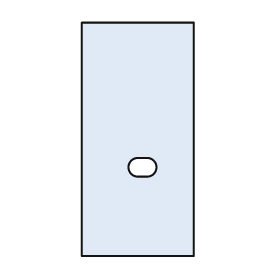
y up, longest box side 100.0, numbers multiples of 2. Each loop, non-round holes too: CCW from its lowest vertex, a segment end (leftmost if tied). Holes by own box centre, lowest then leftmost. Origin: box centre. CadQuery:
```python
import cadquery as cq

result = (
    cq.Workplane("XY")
    .moveTo(-24.0, -50.0)
    .lineTo(24.0, -50.0)
    .lineTo(24.0, 50.0)
    .lineTo(-24.0, 50.0)
    .close()
    .moveTo(0.0, -16.0)
    .lineTo(4.0, -16.0)
    .threePointArc((8.0, -12.0), (4.0, -8.0))
    .lineTo(0.0, -8.0)
    .threePointArc((-4.0, -12.0), (0.0, -16.0))
    .close()
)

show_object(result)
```